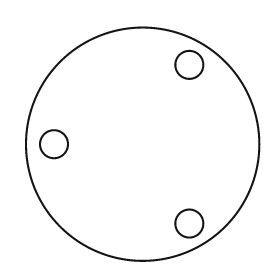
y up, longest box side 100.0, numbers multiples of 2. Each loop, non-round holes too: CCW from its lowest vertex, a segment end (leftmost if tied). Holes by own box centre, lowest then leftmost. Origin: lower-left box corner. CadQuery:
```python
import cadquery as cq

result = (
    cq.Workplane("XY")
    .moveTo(50.0, 50.0)
    .circle(50.0)
    .moveTo(70.0, 16.0)
    .circle(6.0)
    .moveTo(12.0, 50.0)
    .circle(6.0)
    .moveTo(70.0, 84.0)
    .circle(6.0)
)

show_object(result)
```